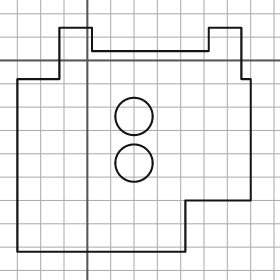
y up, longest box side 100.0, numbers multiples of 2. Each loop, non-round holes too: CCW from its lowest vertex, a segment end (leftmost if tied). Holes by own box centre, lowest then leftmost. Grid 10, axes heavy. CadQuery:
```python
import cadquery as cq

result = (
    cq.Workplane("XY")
    .moveTo(-30.0, -82.0)
    .lineTo(42.0, -82.0)
    .lineTo(42.0, -60.0)
    .lineTo(70.0, -60.0)
    .lineTo(70.0, -8.0)
    .lineTo(66.0, -8.0)
    .lineTo(66.0, 14.0)
    .lineTo(52.0, 14.0)
    .lineTo(52.0, 4.0)
    .lineTo(2.0, 4.0)
    .lineTo(2.0, 14.0)
    .lineTo(-12.0, 14.0)
    .lineTo(-12.0, -8.0)
    .lineTo(-30.0, -8.0)
    .close()
    .moveTo(20.0, -44.0)
    .circle(8.0)
    .moveTo(20.0, -24.0)
    .circle(8.0)
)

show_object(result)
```